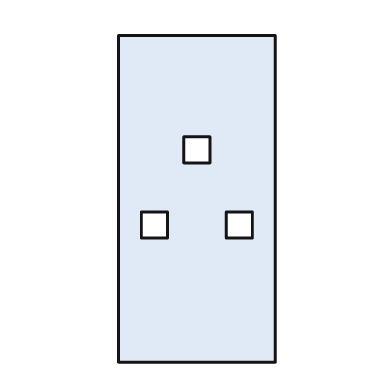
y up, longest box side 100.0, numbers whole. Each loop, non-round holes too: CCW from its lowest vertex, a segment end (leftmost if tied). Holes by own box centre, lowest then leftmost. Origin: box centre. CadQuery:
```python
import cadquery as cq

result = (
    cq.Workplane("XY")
    .moveTo(-24.0, -50.0)
    .lineTo(24.0, -50.0)
    .lineTo(24.0, 50.0)
    .lineTo(-24.0, 50.0)
    .close()
    .moveTo(-17.0, -12.0)
    .lineTo(-9.0, -12.0)
    .lineTo(-9.0, -4.0)
    .lineTo(-17.0, -4.0)
    .close()
    .moveTo(9.0, -12.0)
    .lineTo(17.0, -12.0)
    .lineTo(17.0, -4.0)
    .lineTo(9.0, -4.0)
    .close()
    .moveTo(-4.0, 11.0)
    .lineTo(4.0, 11.0)
    .lineTo(4.0, 19.0)
    .lineTo(-4.0, 19.0)
    .close()
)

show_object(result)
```